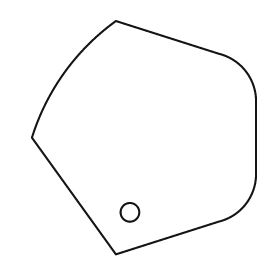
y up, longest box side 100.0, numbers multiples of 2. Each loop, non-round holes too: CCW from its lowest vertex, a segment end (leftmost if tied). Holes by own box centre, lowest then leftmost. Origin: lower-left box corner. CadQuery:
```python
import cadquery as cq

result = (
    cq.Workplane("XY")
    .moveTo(36.0, 0.0)
    .lineTo(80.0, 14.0)
    .threePointArc((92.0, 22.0), (96.0, 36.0))
    .lineTo(96.0, 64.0)
    .threePointArc((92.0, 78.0), (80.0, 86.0))
    .lineTo(36.0, 100.0)
    .threePointArc((14.0, 78.0), (0.0, 50.0))
    .close()
    .moveTo(42.0, 18.0)
    .circle(4.0)
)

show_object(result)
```